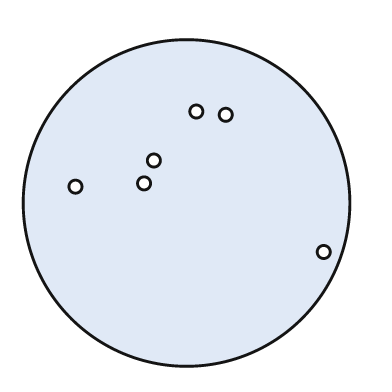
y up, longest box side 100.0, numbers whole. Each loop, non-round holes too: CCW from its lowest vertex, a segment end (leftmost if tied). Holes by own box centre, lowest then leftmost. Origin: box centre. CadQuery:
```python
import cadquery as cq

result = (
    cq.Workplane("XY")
    .moveTo(0.0, 0.0)
    .circle(50.0)
    .moveTo(42.0, -15.0)
    .circle(2.0)
    .moveTo(-34.0, 5.0)
    .circle(2.0)
    .moveTo(-13.0, 6.0)
    .circle(2.0)
    .moveTo(-10.0, 13.0)
    .circle(2.0)
    .moveTo(12.0, 27.0)
    .circle(2.0)
    .moveTo(3.0, 28.0)
    .circle(2.0)
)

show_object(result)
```